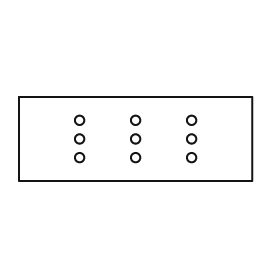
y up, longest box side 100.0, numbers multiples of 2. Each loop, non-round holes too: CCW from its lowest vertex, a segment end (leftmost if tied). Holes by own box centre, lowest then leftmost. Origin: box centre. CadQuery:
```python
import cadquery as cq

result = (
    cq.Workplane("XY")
    .moveTo(-50.0, -18.0)
    .lineTo(50.0, -18.0)
    .lineTo(50.0, 18.0)
    .lineTo(-50.0, 18.0)
    .close()
    .moveTo(-24.0, -8.0)
    .circle(2.0)
    .moveTo(0.0, -8.0)
    .circle(2.0)
    .moveTo(24.0, -8.0)
    .circle(2.0)
    .moveTo(-24.0, 0.0)
    .circle(2.0)
    .moveTo(0.0, 0.0)
    .circle(2.0)
    .moveTo(24.0, 0.0)
    .circle(2.0)
    .moveTo(-24.0, 8.0)
    .circle(2.0)
    .moveTo(0.0, 8.0)
    .circle(2.0)
    .moveTo(24.0, 8.0)
    .circle(2.0)
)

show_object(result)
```